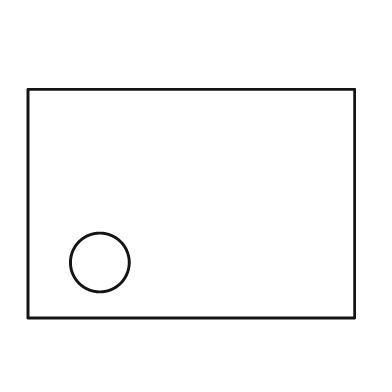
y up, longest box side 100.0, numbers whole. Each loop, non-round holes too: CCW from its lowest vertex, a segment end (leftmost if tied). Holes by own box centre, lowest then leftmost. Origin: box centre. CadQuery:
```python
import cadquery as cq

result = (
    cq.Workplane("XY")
    .moveTo(-50.0, -35.0)
    .lineTo(50.0, -35.0)
    .lineTo(50.0, 35.0)
    .lineTo(-50.0, 35.0)
    .close()
    .moveTo(-28.0, -18.0)
    .circle(9.0)
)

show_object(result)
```